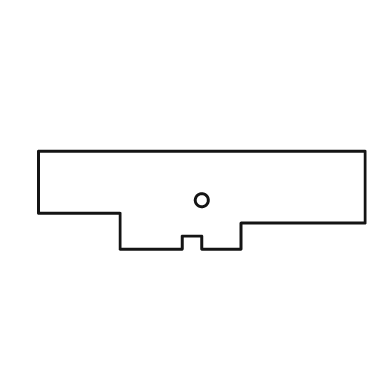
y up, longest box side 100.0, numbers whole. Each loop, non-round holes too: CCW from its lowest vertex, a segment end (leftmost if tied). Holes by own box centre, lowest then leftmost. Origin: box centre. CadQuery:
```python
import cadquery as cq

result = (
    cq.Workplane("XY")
    .moveTo(-25.0, -15.0)
    .lineTo(-6.0, -15.0)
    .lineTo(-6.0, -11.0)
    .lineTo(0.0, -11.0)
    .lineTo(0.0, -15.0)
    .lineTo(12.0, -15.0)
    .lineTo(12.0, -7.0)
    .lineTo(50.0, -7.0)
    .lineTo(50.0, 15.0)
    .lineTo(-50.0, 15.0)
    .lineTo(-50.0, -4.0)
    .lineTo(-25.0, -4.0)
    .close()
    .moveTo(0.0, 0.0)
    .circle(2.0)
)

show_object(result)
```